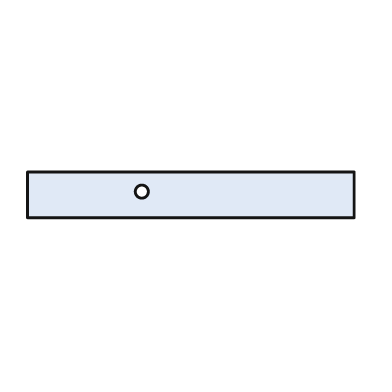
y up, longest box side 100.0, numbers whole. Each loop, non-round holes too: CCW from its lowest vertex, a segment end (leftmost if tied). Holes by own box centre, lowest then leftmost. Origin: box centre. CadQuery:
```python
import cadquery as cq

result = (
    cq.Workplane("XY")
    .moveTo(-50.0, -7.0)
    .lineTo(50.0, -7.0)
    .lineTo(50.0, 7.0)
    .lineTo(-50.0, 7.0)
    .close()
    .moveTo(-15.0, 1.0)
    .circle(2.0)
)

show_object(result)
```